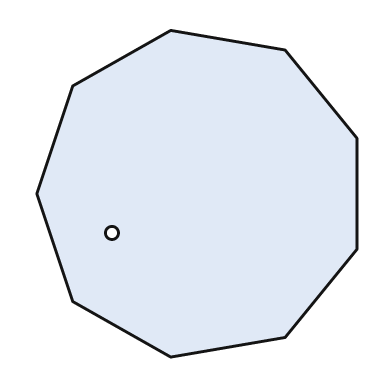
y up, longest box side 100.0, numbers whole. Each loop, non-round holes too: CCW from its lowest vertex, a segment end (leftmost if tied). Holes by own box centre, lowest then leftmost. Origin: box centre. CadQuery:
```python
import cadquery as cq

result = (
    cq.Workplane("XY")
    .moveTo(-8.0, -50.0)
    .lineTo(27.0, -44.0)
    .lineTo(49.0, -17.0)
    .lineTo(49.0, 17.0)
    .lineTo(27.0, 44.0)
    .lineTo(-8.0, 50.0)
    .lineTo(-38.0, 33.0)
    .lineTo(-49.0, 0.0)
    .lineTo(-38.0, -33.0)
    .close()
    .moveTo(-26.0, -12.0)
    .circle(2.0)
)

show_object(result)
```